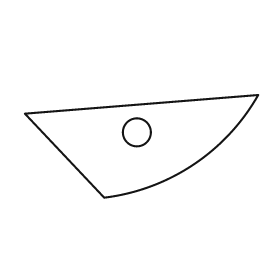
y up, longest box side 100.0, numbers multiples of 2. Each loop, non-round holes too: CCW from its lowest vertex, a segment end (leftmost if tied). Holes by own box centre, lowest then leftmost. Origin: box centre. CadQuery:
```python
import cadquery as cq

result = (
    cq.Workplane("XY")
    .moveTo(-16.0, -22.0)
    .threePointArc((22.0, -8.0), (50.0, 22.0))
    .lineTo(-50.0, 14.0)
    .close()
    .moveTo(-2.0, 6.0)
    .circle(6.0)
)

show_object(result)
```